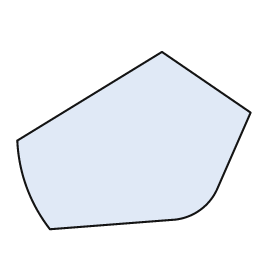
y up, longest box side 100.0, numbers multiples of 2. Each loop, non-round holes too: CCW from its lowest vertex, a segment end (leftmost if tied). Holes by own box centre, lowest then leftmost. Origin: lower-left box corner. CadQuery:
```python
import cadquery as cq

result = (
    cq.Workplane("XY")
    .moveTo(14.0, 0.0)
    .lineTo(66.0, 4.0)
    .threePointArc((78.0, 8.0), (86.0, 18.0))
    .lineTo(100.0, 50.0)
    .lineTo(62.0, 76.0)
    .lineTo(0.0, 38.0)
    .threePointArc((4.0, 18.0), (14.0, 0.0))
    .close()
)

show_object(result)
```